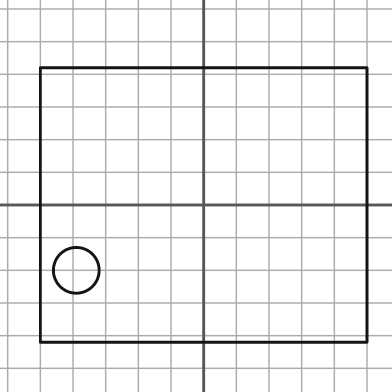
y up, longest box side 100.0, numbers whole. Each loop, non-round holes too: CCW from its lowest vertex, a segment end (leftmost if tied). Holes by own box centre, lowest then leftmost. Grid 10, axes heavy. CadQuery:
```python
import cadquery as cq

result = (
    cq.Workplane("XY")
    .moveTo(-50.0, -42.0)
    .lineTo(50.0, -42.0)
    .lineTo(50.0, 42.0)
    .lineTo(-50.0, 42.0)
    .close()
    .moveTo(-39.0, -20.0)
    .circle(7.0)
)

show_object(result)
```